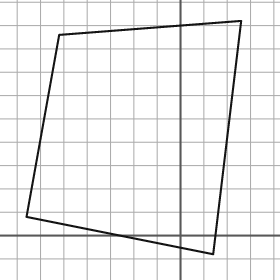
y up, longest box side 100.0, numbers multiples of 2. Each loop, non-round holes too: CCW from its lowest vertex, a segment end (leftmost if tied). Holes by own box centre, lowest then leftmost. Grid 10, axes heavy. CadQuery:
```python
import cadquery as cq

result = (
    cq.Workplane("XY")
    .moveTo(14.0, -8.0)
    .lineTo(26.0, 92.0)
    .lineTo(-52.0, 86.0)
    .lineTo(-66.0, 8.0)
    .close()
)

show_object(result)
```